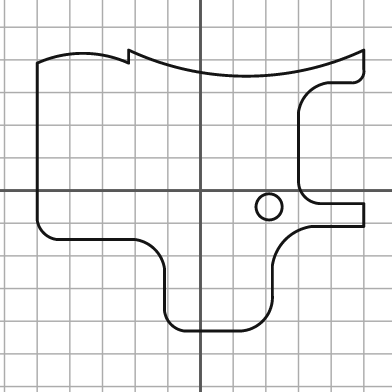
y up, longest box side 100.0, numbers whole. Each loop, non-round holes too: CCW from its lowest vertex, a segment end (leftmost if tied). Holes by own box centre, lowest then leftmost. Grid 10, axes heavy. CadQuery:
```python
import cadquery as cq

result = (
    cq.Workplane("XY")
    .moveTo(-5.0, -43.0)
    .lineTo(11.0, -43.0)
    .threePointArc((19.0, -40.0), (22.0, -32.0))
    .lineTo(22.0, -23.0)
    .threePointArc((26.0, -15.0), (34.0, -11.0))
    .lineTo(50.0, -11.0)
    .lineTo(50.0, -4.0)
    .lineTo(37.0, -4.0)
    .threePointArc((32.0, -2.0), (30.0, 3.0))
    .lineTo(30.0, 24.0)
    .threePointArc((33.0, 30.0), (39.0, 33.0))
    .lineTo(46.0, 33.0)
    .threePointArc((49.0, 34.0), (50.0, 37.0))
    .lineTo(50.0, 43.0)
    .threePointArc((14.0, 35.0), (-22.0, 43.0))
    .lineTo(-22.0, 39.0)
    .threePointArc((-36.0, 42.0), (-50.0, 39.0))
    .lineTo(-50.0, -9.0)
    .threePointArc((-48.0, -13.0), (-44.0, -15.0))
    .lineTo(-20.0, -15.0)
    .threePointArc((-14.0, -18.0), (-11.0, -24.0))
    .lineTo(-11.0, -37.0)
    .threePointArc((-9.0, -41.0), (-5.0, -43.0))
    .close()
    .moveTo(21.0, -5.0)
    .circle(4.0)
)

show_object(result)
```